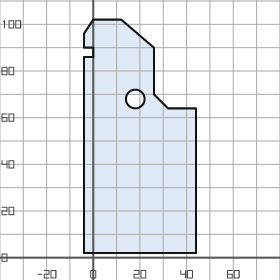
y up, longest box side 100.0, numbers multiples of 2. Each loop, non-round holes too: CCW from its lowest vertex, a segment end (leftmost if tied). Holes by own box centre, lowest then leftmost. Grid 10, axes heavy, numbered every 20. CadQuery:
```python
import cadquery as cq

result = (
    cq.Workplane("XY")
    .moveTo(-4.0, 2.0)
    .lineTo(44.0, 2.0)
    .lineTo(44.0, 64.0)
    .lineTo(32.0, 64.0)
    .lineTo(26.0, 70.0)
    .lineTo(26.0, 90.0)
    .lineTo(12.0, 102.0)
    .lineTo(0.0, 102.0)
    .lineTo(-4.0, 96.0)
    .lineTo(-4.0, 90.0)
    .lineTo(0.0, 90.0)
    .lineTo(0.0, 86.0)
    .lineTo(-4.0, 86.0)
    .close()
    .moveTo(18.0, 68.0)
    .circle(4.0)
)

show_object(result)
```